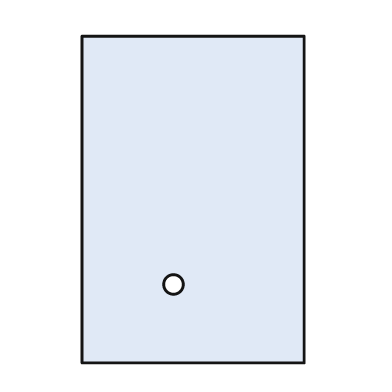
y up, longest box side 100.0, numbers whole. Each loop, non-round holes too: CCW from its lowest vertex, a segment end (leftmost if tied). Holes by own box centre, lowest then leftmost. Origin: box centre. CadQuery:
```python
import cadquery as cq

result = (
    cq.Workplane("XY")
    .moveTo(-34.0, -50.0)
    .lineTo(34.0, -50.0)
    .lineTo(34.0, 50.0)
    .lineTo(-34.0, 50.0)
    .close()
    .moveTo(-6.0, -26.0)
    .circle(3.0)
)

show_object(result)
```